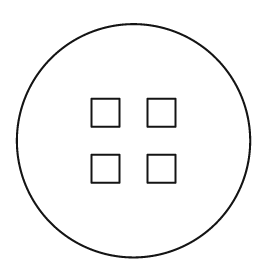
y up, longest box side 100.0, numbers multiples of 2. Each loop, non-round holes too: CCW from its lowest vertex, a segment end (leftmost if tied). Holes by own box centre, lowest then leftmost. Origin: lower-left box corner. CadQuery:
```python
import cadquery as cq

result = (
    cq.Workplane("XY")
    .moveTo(50.0, 50.0)
    .circle(50.0)
    .moveTo(32.0, 32.0)
    .lineTo(44.0, 32.0)
    .lineTo(44.0, 44.0)
    .lineTo(32.0, 44.0)
    .close()
    .moveTo(56.0, 32.0)
    .lineTo(68.0, 32.0)
    .lineTo(68.0, 44.0)
    .lineTo(56.0, 44.0)
    .close()
    .moveTo(32.0, 56.0)
    .lineTo(44.0, 56.0)
    .lineTo(44.0, 68.0)
    .lineTo(32.0, 68.0)
    .close()
    .moveTo(56.0, 56.0)
    .lineTo(68.0, 56.0)
    .lineTo(68.0, 68.0)
    .lineTo(56.0, 68.0)
    .close()
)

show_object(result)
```